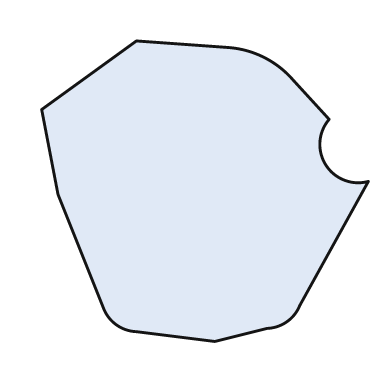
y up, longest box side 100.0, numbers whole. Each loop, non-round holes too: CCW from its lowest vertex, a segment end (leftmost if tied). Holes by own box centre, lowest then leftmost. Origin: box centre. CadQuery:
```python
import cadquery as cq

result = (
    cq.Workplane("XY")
    .moveTo(3.0, -46.0)
    .lineTo(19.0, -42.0)
    .threePointArc((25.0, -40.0), (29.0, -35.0))
    .lineTo(50.0, 3.0)
    .threePointArc((37.0, 8.0), (38.0, 22.0))
    .lineTo(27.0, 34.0)
    .threePointArc((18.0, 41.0), (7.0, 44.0))
    .lineTo(-21.0, 46.0)
    .lineTo(-50.0, 25.0)
    .lineTo(-45.0, -1.0)
    .lineTo(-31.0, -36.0)
    .threePointArc((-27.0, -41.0), (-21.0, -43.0))
    .close()
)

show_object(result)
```